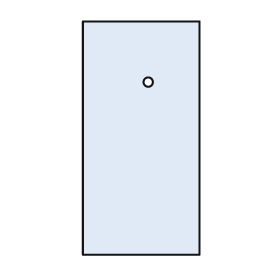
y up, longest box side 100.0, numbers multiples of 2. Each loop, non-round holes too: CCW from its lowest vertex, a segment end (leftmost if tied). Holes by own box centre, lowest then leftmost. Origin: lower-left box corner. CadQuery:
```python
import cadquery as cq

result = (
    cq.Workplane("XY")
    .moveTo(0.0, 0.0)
    .lineTo(50.0, 0.0)
    .lineTo(50.0, 100.0)
    .lineTo(0.0, 100.0)
    .close()
    .moveTo(28.0, 74.0)
    .circle(2.0)
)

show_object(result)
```